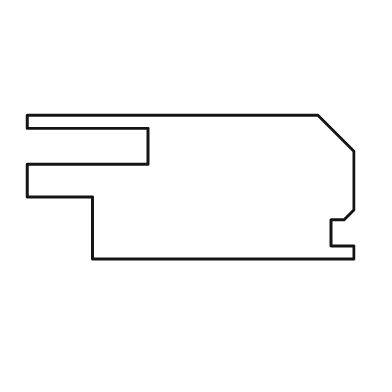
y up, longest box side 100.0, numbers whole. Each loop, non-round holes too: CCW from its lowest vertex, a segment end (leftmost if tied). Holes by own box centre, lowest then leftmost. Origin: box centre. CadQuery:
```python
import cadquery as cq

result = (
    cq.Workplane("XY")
    .moveTo(-30.0, -22.0)
    .lineTo(50.0, -22.0)
    .lineTo(50.0, -18.0)
    .lineTo(43.0, -18.0)
    .lineTo(43.0, -10.0)
    .lineTo(47.0, -10.0)
    .lineTo(50.0, -7.0)
    .lineTo(50.0, 11.0)
    .lineTo(39.0, 22.0)
    .lineTo(-50.0, 22.0)
    .lineTo(-50.0, 18.0)
    .lineTo(-13.0, 18.0)
    .lineTo(-13.0, 7.0)
    .lineTo(-50.0, 7.0)
    .lineTo(-50.0, -3.0)
    .lineTo(-30.0, -3.0)
    .close()
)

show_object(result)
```